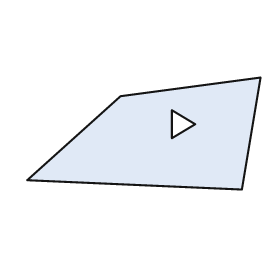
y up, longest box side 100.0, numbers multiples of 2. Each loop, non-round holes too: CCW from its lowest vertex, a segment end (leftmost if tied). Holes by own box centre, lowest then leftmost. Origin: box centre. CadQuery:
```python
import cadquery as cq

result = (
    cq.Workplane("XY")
    .moveTo(42.0, -24.0)
    .lineTo(50.0, 24.0)
    .lineTo(-10.0, 16.0)
    .lineTo(-50.0, -20.0)
    .close()
    .moveTo(12.0, -2.0)
    .lineTo(22.0, 4.0)
    .lineTo(12.0, 10.0)
    .close()
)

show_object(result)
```